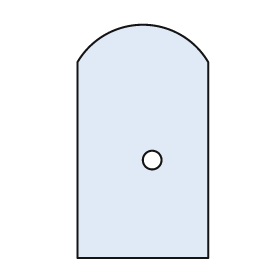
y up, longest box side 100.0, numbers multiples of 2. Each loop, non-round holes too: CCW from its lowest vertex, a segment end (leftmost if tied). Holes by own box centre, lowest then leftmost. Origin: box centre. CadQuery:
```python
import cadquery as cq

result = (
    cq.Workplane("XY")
    .moveTo(-28.0, -50.0)
    .lineTo(28.0, -50.0)
    .lineTo(28.0, 34.0)
    .threePointArc((0.0, 50.0), (-28.0, 34.0))
    .close()
    .moveTo(4.0, -8.0)
    .circle(4.0)
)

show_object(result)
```